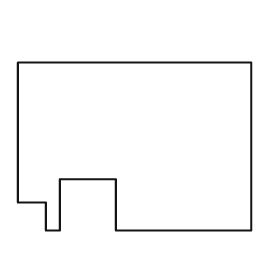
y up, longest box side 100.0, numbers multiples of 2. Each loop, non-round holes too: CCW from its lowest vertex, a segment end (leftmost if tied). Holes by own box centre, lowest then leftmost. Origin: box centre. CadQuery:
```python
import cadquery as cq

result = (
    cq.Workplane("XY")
    .moveTo(-38.0, -36.0)
    .lineTo(-32.0, -36.0)
    .lineTo(-32.0, -14.0)
    .lineTo(-8.0, -14.0)
    .lineTo(-8.0, -36.0)
    .lineTo(50.0, -36.0)
    .lineTo(50.0, 36.0)
    .lineTo(-50.0, 36.0)
    .lineTo(-50.0, -24.0)
    .lineTo(-38.0, -24.0)
    .close()
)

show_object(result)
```